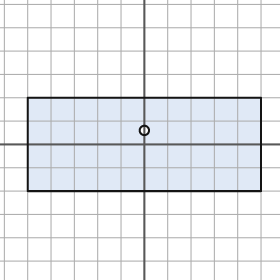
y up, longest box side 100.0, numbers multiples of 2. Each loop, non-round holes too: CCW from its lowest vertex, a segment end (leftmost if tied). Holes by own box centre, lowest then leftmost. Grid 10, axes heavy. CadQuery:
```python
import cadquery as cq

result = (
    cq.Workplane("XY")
    .moveTo(-50.0, -20.0)
    .lineTo(50.0, -20.0)
    .lineTo(50.0, 20.0)
    .lineTo(-50.0, 20.0)
    .close()
    .moveTo(0.0, 6.0)
    .circle(2.0)
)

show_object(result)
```